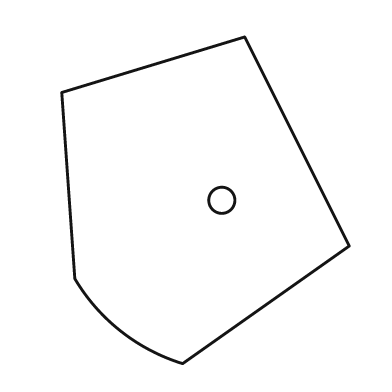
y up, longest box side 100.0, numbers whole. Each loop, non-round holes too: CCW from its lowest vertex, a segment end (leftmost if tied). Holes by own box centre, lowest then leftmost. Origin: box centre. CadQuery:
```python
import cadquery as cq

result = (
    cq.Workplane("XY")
    .moveTo(-7.0, -50.0)
    .lineTo(44.0, -14.0)
    .lineTo(12.0, 50.0)
    .lineTo(-44.0, 33.0)
    .lineTo(-40.0, -24.0)
    .threePointArc((-26.0, -40.0), (-7.0, -50.0))
    .close()
    .moveTo(5.0, 0.0)
    .circle(4.0)
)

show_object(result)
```